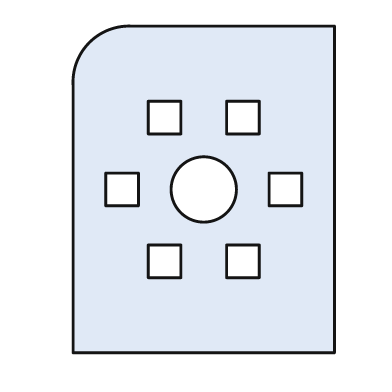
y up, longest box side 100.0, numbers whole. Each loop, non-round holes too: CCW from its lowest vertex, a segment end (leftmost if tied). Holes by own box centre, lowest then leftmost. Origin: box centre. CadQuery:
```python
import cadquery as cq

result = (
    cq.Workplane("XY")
    .moveTo(-40.0, -50.0)
    .lineTo(40.0, -50.0)
    .lineTo(40.0, 50.0)
    .lineTo(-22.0, 50.0)
    .threePointArc((-35.0, 45.0), (-40.0, 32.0))
    .close()
    .moveTo(-17.0, -27.0)
    .lineTo(-7.0, -27.0)
    .lineTo(-7.0, -17.0)
    .lineTo(-17.0, -17.0)
    .close()
    .moveTo(7.0, -27.0)
    .lineTo(17.0, -27.0)
    .lineTo(17.0, -17.0)
    .lineTo(7.0, -17.0)
    .close()
    .moveTo(-30.0, -5.0)
    .lineTo(-20.0, -5.0)
    .lineTo(-20.0, 5.0)
    .lineTo(-30.0, 5.0)
    .close()
    .moveTo(0.0, 0.0)
    .circle(10.0)
    .moveTo(20.0, -5.0)
    .lineTo(30.0, -5.0)
    .lineTo(30.0, 5.0)
    .lineTo(20.0, 5.0)
    .close()
    .moveTo(-17.0, 17.0)
    .lineTo(-7.0, 17.0)
    .lineTo(-7.0, 27.0)
    .lineTo(-17.0, 27.0)
    .close()
    .moveTo(7.0, 17.0)
    .lineTo(17.0, 17.0)
    .lineTo(17.0, 27.0)
    .lineTo(7.0, 27.0)
    .close()
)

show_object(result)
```